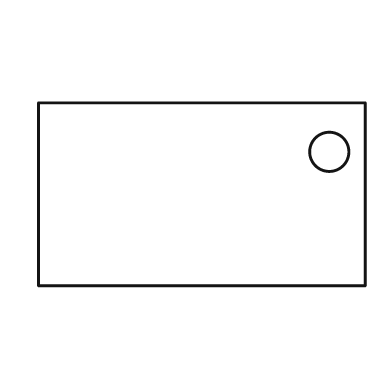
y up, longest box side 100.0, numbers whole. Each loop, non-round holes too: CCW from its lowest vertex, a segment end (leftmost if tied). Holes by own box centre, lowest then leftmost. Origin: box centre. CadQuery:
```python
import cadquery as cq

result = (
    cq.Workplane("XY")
    .moveTo(-50.0, -28.0)
    .lineTo(50.0, -28.0)
    .lineTo(50.0, 28.0)
    .lineTo(-50.0, 28.0)
    .close()
    .moveTo(39.0, 13.0)
    .circle(6.0)
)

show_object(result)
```